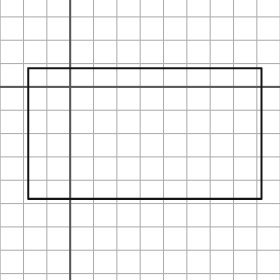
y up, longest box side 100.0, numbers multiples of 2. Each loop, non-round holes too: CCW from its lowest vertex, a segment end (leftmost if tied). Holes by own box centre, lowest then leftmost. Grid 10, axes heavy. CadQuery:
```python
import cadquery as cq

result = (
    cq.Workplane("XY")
    .moveTo(-18.0, -48.0)
    .lineTo(82.0, -48.0)
    .lineTo(82.0, 8.0)
    .lineTo(-18.0, 8.0)
    .close()
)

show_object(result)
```